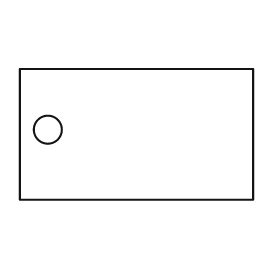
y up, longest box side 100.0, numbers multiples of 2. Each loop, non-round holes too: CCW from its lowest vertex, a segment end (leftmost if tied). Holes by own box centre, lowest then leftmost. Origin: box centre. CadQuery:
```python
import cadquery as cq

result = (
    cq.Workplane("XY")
    .moveTo(-50.0, -28.0)
    .lineTo(50.0, -28.0)
    .lineTo(50.0, 28.0)
    .lineTo(-50.0, 28.0)
    .close()
    .moveTo(-38.0, 2.0)
    .circle(6.0)
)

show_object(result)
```